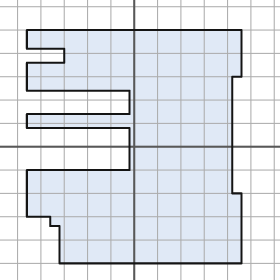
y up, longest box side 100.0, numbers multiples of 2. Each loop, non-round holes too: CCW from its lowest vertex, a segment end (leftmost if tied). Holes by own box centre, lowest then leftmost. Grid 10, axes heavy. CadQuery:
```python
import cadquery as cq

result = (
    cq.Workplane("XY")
    .moveTo(-32.0, -50.0)
    .lineTo(46.0, -50.0)
    .lineTo(46.0, -20.0)
    .lineTo(42.0, -20.0)
    .lineTo(42.0, 30.0)
    .lineTo(46.0, 30.0)
    .lineTo(46.0, 50.0)
    .lineTo(-46.0, 50.0)
    .lineTo(-46.0, 42.0)
    .lineTo(-30.0, 42.0)
    .lineTo(-30.0, 36.0)
    .lineTo(-46.0, 36.0)
    .lineTo(-46.0, 24.0)
    .lineTo(-2.0, 24.0)
    .lineTo(-2.0, 14.0)
    .lineTo(-46.0, 14.0)
    .lineTo(-46.0, 8.0)
    .lineTo(-2.0, 8.0)
    .lineTo(-2.0, -10.0)
    .lineTo(-46.0, -10.0)
    .lineTo(-46.0, -30.0)
    .lineTo(-36.0, -30.0)
    .lineTo(-36.0, -34.0)
    .lineTo(-32.0, -34.0)
    .close()
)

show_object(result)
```